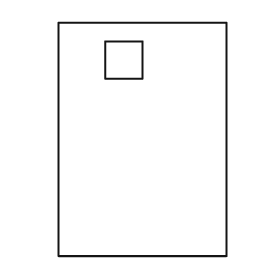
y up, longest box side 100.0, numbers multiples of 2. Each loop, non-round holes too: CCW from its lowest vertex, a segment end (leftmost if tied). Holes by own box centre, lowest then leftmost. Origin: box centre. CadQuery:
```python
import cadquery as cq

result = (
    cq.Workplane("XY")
    .moveTo(-36.0, -50.0)
    .lineTo(36.0, -50.0)
    .lineTo(36.0, 50.0)
    .lineTo(-36.0, 50.0)
    .close()
    .moveTo(-16.0, 26.0)
    .lineTo(0.0, 26.0)
    .lineTo(0.0, 42.0)
    .lineTo(-16.0, 42.0)
    .close()
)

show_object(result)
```